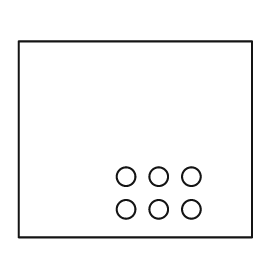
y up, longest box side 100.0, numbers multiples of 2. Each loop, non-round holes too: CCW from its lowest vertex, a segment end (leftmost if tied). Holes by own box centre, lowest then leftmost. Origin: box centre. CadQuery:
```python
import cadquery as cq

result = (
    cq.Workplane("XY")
    .moveTo(-50.0, -42.0)
    .lineTo(50.0, -42.0)
    .lineTo(50.0, 42.0)
    .lineTo(-50.0, 42.0)
    .close()
    .moveTo(-4.0, -30.0)
    .circle(4.0)
    .moveTo(10.0, -30.0)
    .circle(4.0)
    .moveTo(24.0, -30.0)
    .circle(4.0)
    .moveTo(-4.0, -16.0)
    .circle(4.0)
    .moveTo(10.0, -16.0)
    .circle(4.0)
    .moveTo(24.0, -16.0)
    .circle(4.0)
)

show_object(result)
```